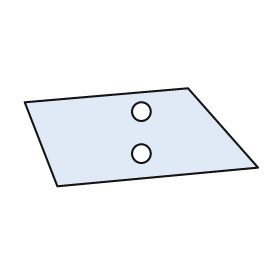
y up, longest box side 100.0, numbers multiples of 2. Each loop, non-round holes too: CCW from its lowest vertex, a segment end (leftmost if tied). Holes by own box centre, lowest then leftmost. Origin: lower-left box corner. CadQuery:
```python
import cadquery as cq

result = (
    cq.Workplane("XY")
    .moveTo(14.0, 0.0)
    .lineTo(100.0, 8.0)
    .lineTo(70.0, 42.0)
    .lineTo(0.0, 36.0)
    .close()
    .moveTo(50.0, 14.0)
    .circle(4.0)
    .moveTo(50.0, 32.0)
    .circle(4.0)
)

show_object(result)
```